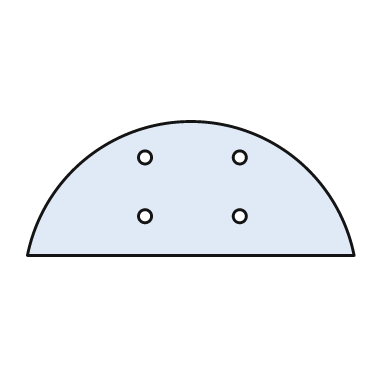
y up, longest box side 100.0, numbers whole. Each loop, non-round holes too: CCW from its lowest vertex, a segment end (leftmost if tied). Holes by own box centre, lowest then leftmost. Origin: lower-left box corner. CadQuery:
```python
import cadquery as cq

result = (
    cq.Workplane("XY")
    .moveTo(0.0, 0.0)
    .lineTo(100.0, 0.0)
    .threePointArc((50.0, 41.0), (0.0, 0.0))
    .close()
    .moveTo(36.0, 12.0)
    .circle(2.0)
    .moveTo(65.0, 12.0)
    .circle(2.0)
    .moveTo(36.0, 30.0)
    .circle(2.0)
    .moveTo(65.0, 30.0)
    .circle(2.0)
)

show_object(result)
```